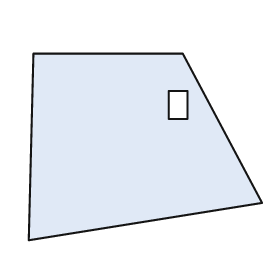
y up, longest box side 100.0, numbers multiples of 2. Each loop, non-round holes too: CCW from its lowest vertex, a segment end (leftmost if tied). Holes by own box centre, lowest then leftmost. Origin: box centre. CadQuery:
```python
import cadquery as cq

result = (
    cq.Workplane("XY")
    .moveTo(-50.0, -40.0)
    .lineTo(50.0, -24.0)
    .lineTo(16.0, 40.0)
    .lineTo(-48.0, 40.0)
    .close()
    .moveTo(10.0, 12.0)
    .lineTo(18.0, 12.0)
    .lineTo(18.0, 24.0)
    .lineTo(10.0, 24.0)
    .close()
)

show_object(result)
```